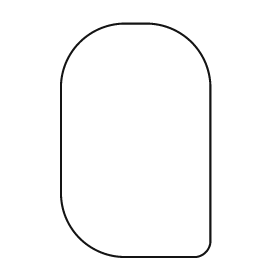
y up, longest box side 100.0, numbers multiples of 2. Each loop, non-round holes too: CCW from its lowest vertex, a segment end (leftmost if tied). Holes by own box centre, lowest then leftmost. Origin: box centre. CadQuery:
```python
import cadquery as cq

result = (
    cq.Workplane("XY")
    .moveTo(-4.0, -50.0)
    .lineTo(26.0, -50.0)
    .threePointArc((30.0, -48.0), (32.0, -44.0))
    .lineTo(32.0, 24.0)
    .threePointArc((24.0, 42.0), (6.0, 50.0))
    .lineTo(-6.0, 50.0)
    .threePointArc((-24.0, 42.0), (-32.0, 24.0))
    .lineTo(-32.0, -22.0)
    .threePointArc((-24.0, -42.0), (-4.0, -50.0))
    .close()
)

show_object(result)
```